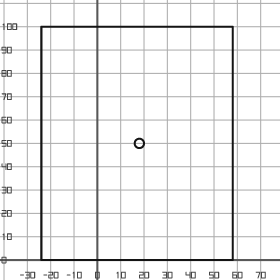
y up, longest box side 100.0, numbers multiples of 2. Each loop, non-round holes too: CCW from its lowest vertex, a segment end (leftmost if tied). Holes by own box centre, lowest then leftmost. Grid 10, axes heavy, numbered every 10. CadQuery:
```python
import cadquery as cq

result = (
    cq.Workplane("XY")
    .moveTo(-24.0, 0.0)
    .lineTo(58.0, 0.0)
    .lineTo(58.0, 100.0)
    .lineTo(-24.0, 100.0)
    .close()
    .moveTo(18.0, 50.0)
    .circle(2.0)
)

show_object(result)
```